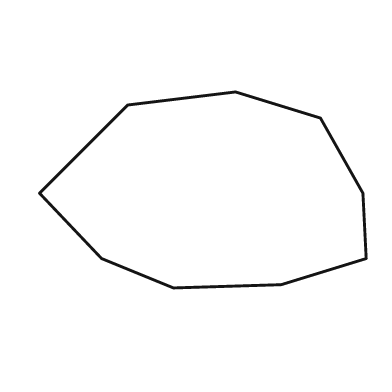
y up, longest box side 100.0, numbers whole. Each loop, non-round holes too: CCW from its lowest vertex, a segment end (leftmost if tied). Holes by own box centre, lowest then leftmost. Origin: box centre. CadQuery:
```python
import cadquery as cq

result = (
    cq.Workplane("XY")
    .moveTo(-9.0, -30.0)
    .lineTo(24.0, -29.0)
    .lineTo(50.0, -21.0)
    .lineTo(49.0, -1.0)
    .lineTo(36.0, 22.0)
    .lineTo(10.0, 30.0)
    .lineTo(-23.0, 26.0)
    .lineTo(-50.0, -1.0)
    .lineTo(-31.0, -21.0)
    .close()
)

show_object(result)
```